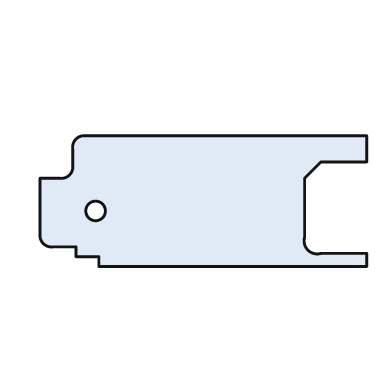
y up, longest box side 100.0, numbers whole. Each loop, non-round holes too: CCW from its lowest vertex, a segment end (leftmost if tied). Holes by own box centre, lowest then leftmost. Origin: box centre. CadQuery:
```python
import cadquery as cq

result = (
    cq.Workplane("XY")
    .moveTo(-32.0, -20.0)
    .lineTo(50.0, -20.0)
    .lineTo(50.0, -16.0)
    .lineTo(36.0, -16.0)
    .threePointArc((32.0, -15.0), (31.0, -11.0))
    .lineTo(31.0, 7.0)
    .lineTo(36.0, 12.0)
    .lineTo(50.0, 12.0)
    .lineTo(50.0, 20.0)
    .lineTo(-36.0, 20.0)
    .threePointArc((-39.0, 19.0), (-40.0, 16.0))
    .lineTo(-40.0, 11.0)
    .threePointArc((-41.0, 8.0), (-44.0, 7.0))
    .lineTo(-50.0, 7.0)
    .lineTo(-50.0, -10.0)
    .threePointArc((-49.0, -13.0), (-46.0, -14.0))
    .lineTo(-39.0, -14.0)
    .lineTo(-39.0, -17.0)
    .lineTo(-32.0, -17.0)
    .close()
    .moveTo(-33.0, -3.0)
    .circle(3.0)
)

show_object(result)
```